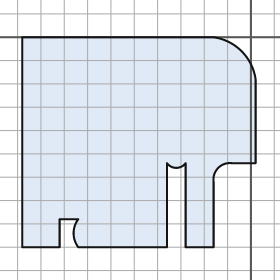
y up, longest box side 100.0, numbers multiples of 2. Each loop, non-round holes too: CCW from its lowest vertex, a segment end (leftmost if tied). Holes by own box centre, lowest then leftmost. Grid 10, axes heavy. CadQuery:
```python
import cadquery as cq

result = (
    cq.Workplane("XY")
    .moveTo(-98.0, -90.0)
    .lineTo(-82.0, -90.0)
    .lineTo(-82.0, -78.0)
    .lineTo(-74.0, -78.0)
    .threePointArc((-76.0, -84.0), (-74.0, -90.0))
    .lineTo(-36.0, -90.0)
    .lineTo(-36.0, -54.0)
    .threePointArc((-32.0, -56.0), (-28.0, -54.0))
    .lineTo(-28.0, -90.0)
    .lineTo(-16.0, -90.0)
    .lineTo(-16.0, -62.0)
    .threePointArc((-14.0, -56.0), (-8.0, -54.0))
    .lineTo(2.0, -54.0)
    .lineTo(2.0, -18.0)
    .threePointArc((-4.0, -6.0), (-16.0, 0.0))
    .lineTo(-98.0, 0.0)
    .close()
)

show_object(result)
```